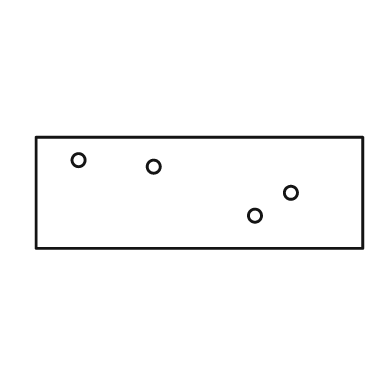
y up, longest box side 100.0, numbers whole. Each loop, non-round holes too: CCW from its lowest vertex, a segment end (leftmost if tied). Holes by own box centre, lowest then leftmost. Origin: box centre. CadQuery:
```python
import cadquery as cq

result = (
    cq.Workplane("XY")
    .moveTo(-50.0, -17.0)
    .lineTo(50.0, -17.0)
    .lineTo(50.0, 17.0)
    .lineTo(-50.0, 17.0)
    .close()
    .moveTo(17.0, -7.0)
    .circle(2.0)
    .moveTo(28.0, 0.0)
    .circle(2.0)
    .moveTo(-14.0, 8.0)
    .circle(2.0)
    .moveTo(-37.0, 10.0)
    .circle(2.0)
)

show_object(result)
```